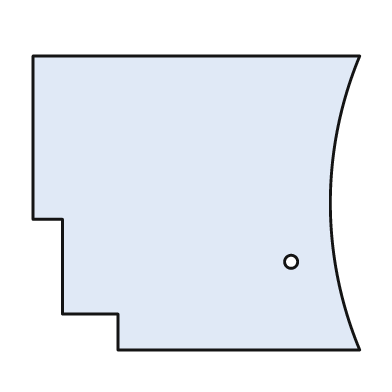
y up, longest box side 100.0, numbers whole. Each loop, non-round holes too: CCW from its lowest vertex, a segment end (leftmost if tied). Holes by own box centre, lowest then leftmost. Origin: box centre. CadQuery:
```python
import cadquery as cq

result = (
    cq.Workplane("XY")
    .moveTo(-24.0, -45.0)
    .lineTo(50.0, -45.0)
    .threePointArc((41.0, 0.0), (50.0, 45.0))
    .lineTo(-50.0, 45.0)
    .lineTo(-50.0, -5.0)
    .lineTo(-41.0, -5.0)
    .lineTo(-41.0, -34.0)
    .lineTo(-24.0, -34.0)
    .close()
    .moveTo(29.0, -18.0)
    .circle(2.0)
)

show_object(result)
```